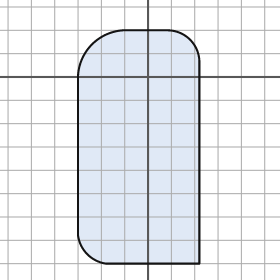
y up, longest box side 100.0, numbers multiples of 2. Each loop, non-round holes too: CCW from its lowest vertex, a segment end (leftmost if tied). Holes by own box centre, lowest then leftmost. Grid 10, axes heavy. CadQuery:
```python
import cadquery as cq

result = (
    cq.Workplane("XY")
    .moveTo(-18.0, -80.0)
    .lineTo(22.0, -80.0)
    .lineTo(22.0, 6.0)
    .threePointArc((18.0, 16.0), (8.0, 20.0))
    .lineTo(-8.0, 20.0)
    .threePointArc((-24.0, 14.0), (-30.0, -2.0))
    .lineTo(-30.0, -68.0)
    .threePointArc((-26.0, -76.0), (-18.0, -80.0))
    .close()
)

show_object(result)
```